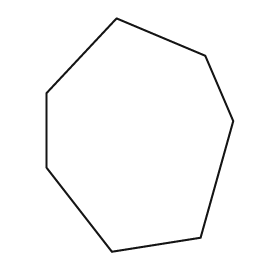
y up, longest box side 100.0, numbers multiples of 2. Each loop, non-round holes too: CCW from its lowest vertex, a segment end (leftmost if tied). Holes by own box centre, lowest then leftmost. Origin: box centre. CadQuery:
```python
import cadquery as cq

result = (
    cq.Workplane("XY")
    .moveTo(-12.0, -50.0)
    .lineTo(26.0, -44.0)
    .lineTo(40.0, 6.0)
    .lineTo(28.0, 34.0)
    .lineTo(-10.0, 50.0)
    .lineTo(-40.0, 18.0)
    .lineTo(-40.0, -14.0)
    .close()
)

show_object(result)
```